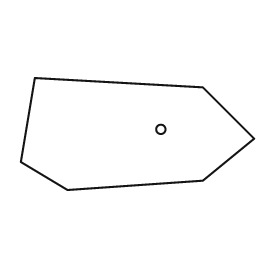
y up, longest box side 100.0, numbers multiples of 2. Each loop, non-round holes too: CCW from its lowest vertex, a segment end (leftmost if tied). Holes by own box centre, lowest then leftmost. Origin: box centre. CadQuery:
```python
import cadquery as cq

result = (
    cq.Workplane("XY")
    .moveTo(-30.0, -24.0)
    .lineTo(28.0, -20.0)
    .lineTo(50.0, -2.0)
    .lineTo(28.0, 20.0)
    .lineTo(-44.0, 24.0)
    .lineTo(-50.0, -12.0)
    .close()
    .moveTo(10.0, 2.0)
    .circle(2.0)
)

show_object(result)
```